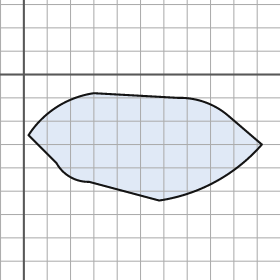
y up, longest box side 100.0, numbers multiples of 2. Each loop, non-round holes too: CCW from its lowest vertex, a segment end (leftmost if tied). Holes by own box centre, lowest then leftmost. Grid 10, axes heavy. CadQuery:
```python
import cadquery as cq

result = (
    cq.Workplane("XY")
    .moveTo(58.0, -54.0)
    .threePointArc((82.0, -46.0), (102.0, -30.0))
    .lineTo(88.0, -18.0)
    .threePointArc((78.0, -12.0), (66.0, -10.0))
    .lineTo(30.0, -8.0)
    .threePointArc((14.0, -14.0), (2.0, -26.0))
    .lineTo(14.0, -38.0)
    .threePointArc((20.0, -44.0), (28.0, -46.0))
    .close()
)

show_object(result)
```